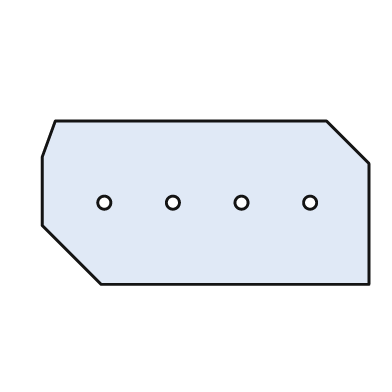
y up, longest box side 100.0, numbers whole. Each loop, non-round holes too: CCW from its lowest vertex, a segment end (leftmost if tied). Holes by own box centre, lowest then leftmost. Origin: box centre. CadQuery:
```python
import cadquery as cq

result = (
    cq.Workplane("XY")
    .moveTo(-32.0, -25.0)
    .lineTo(50.0, -25.0)
    .lineTo(50.0, 12.0)
    .lineTo(37.0, 25.0)
    .lineTo(-46.0, 25.0)
    .lineTo(-50.0, 14.0)
    .lineTo(-50.0, -7.0)
    .close()
    .moveTo(-31.0, 0.0)
    .circle(2.0)
    .moveTo(-10.0, 0.0)
    .circle(2.0)
    .moveTo(11.0, 0.0)
    .circle(2.0)
    .moveTo(32.0, 0.0)
    .circle(2.0)
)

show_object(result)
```